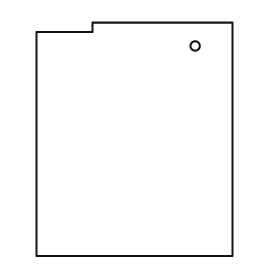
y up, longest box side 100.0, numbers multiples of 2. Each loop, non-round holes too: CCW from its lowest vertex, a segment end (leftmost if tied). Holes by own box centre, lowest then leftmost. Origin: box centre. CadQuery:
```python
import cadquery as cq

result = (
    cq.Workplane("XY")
    .moveTo(-42.0, -50.0)
    .lineTo(42.0, -50.0)
    .lineTo(42.0, 50.0)
    .lineTo(-18.0, 50.0)
    .lineTo(-18.0, 46.0)
    .lineTo(-42.0, 46.0)
    .close()
    .moveTo(26.0, 40.0)
    .circle(2.0)
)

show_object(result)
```